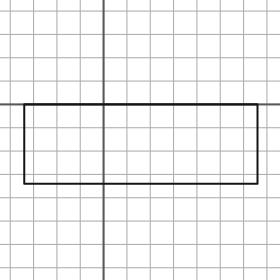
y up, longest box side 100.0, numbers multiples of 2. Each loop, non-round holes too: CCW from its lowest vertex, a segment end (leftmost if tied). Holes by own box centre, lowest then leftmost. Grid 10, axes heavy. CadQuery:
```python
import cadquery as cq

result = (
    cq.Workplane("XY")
    .moveTo(-34.0, -34.0)
    .lineTo(66.0, -34.0)
    .lineTo(66.0, 0.0)
    .lineTo(-34.0, 0.0)
    .close()
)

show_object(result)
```